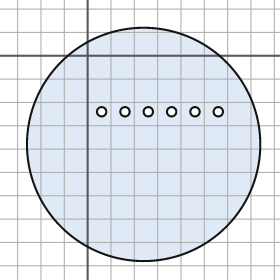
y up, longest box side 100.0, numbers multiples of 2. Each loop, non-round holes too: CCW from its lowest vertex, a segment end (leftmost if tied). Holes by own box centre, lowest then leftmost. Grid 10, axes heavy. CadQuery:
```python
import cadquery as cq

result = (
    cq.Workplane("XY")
    .moveTo(24.0, -38.0)
    .circle(50.0)
    .moveTo(6.0, -24.0)
    .circle(2.0)
    .moveTo(16.0, -24.0)
    .circle(2.0)
    .moveTo(26.0, -24.0)
    .circle(2.0)
    .moveTo(36.0, -24.0)
    .circle(2.0)
    .moveTo(46.0, -24.0)
    .circle(2.0)
    .moveTo(56.0, -24.0)
    .circle(2.0)
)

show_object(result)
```